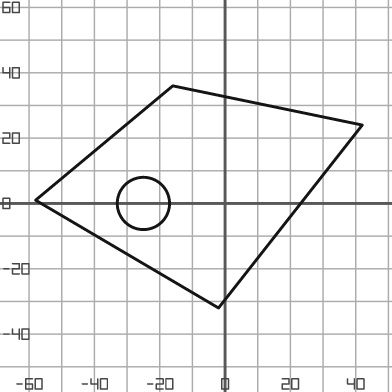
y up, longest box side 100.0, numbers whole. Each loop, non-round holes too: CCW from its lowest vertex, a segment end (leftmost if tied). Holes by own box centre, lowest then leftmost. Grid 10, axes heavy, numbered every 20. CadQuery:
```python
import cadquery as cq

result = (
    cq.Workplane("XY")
    .moveTo(-2.0, -32.0)
    .lineTo(42.0, 24.0)
    .lineTo(-16.0, 36.0)
    .lineTo(-58.0, 1.0)
    .close()
    .moveTo(-25.0, 0.0)
    .circle(8.0)
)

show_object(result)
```